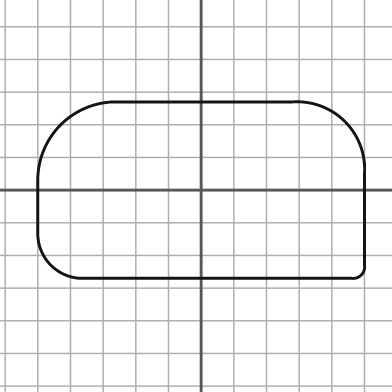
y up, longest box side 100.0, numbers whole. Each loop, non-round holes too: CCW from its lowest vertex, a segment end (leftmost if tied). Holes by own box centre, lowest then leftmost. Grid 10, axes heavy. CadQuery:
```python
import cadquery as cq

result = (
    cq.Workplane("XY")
    .moveTo(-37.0, -27.0)
    .lineTo(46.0, -27.0)
    .threePointArc((49.0, -26.0), (50.0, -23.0))
    .lineTo(50.0, 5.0)
    .threePointArc((44.0, 21.0), (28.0, 27.0))
    .lineTo(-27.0, 27.0)
    .threePointArc((-43.0, 20.0), (-50.0, 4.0))
    .lineTo(-50.0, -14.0)
    .threePointArc((-46.0, -23.0), (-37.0, -27.0))
    .close()
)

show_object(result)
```